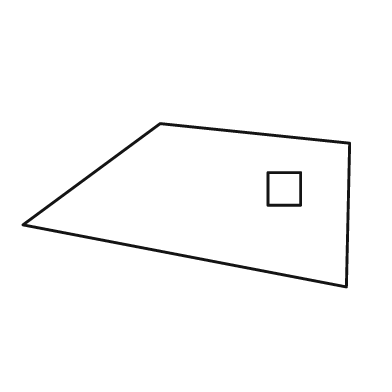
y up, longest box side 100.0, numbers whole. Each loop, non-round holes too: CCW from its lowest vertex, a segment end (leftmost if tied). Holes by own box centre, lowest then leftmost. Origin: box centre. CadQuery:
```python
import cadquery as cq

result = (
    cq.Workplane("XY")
    .moveTo(49.0, -25.0)
    .lineTo(50.0, 19.0)
    .lineTo(-8.0, 25.0)
    .lineTo(-50.0, -6.0)
    .close()
    .moveTo(25.0, 0.0)
    .lineTo(35.0, 0.0)
    .lineTo(35.0, 10.0)
    .lineTo(25.0, 10.0)
    .close()
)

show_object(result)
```